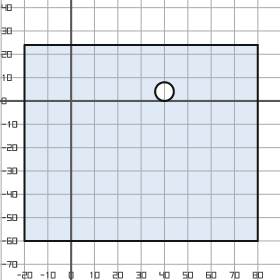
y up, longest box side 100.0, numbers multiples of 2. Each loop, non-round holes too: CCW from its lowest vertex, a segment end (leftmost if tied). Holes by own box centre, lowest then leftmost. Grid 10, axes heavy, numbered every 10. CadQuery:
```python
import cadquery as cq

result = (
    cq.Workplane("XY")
    .moveTo(-20.0, -60.0)
    .lineTo(80.0, -60.0)
    .lineTo(80.0, 24.0)
    .lineTo(-20.0, 24.0)
    .close()
    .moveTo(40.0, 4.0)
    .circle(4.0)
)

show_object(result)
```